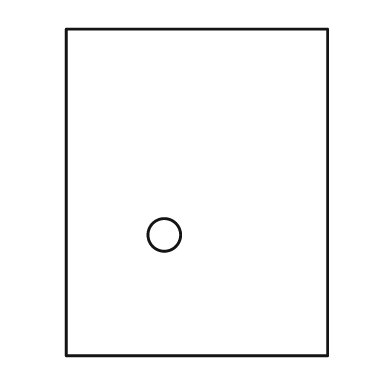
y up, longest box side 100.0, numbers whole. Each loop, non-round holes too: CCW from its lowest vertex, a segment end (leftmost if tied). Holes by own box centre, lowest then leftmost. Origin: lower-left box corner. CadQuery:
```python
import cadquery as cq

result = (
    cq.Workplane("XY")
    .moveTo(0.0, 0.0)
    .lineTo(80.0, 0.0)
    .lineTo(80.0, 100.0)
    .lineTo(0.0, 100.0)
    .close()
    .moveTo(30.0, 37.0)
    .circle(5.0)
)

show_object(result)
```